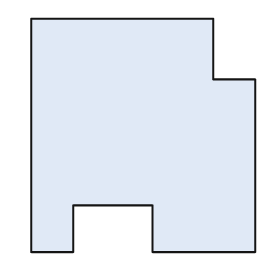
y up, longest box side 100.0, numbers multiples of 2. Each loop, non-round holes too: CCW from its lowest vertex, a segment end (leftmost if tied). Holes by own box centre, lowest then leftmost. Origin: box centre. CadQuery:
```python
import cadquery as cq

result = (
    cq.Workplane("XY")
    .moveTo(-48.0, -50.0)
    .lineTo(-30.0, -50.0)
    .lineTo(-30.0, -30.0)
    .lineTo(4.0, -30.0)
    .lineTo(4.0, -50.0)
    .lineTo(48.0, -50.0)
    .lineTo(48.0, 24.0)
    .lineTo(30.0, 24.0)
    .lineTo(30.0, 50.0)
    .lineTo(-48.0, 50.0)
    .close()
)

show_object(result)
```